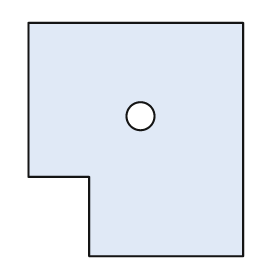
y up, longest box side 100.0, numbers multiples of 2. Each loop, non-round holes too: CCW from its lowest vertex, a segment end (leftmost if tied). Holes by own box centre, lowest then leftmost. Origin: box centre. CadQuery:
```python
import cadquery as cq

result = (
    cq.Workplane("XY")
    .moveTo(-20.0, -50.0)
    .lineTo(46.0, -50.0)
    .lineTo(46.0, 50.0)
    .lineTo(-46.0, 50.0)
    .lineTo(-46.0, -16.0)
    .lineTo(-20.0, -16.0)
    .close()
    .moveTo(2.0, 10.0)
    .circle(6.0)
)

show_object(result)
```